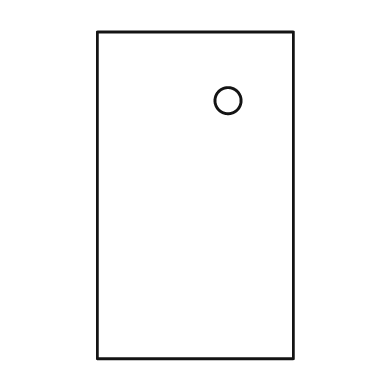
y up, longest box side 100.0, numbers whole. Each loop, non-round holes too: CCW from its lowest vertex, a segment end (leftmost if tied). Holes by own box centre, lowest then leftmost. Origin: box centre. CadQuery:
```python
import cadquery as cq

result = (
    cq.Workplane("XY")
    .moveTo(-30.0, -50.0)
    .lineTo(30.0, -50.0)
    .lineTo(30.0, 50.0)
    .lineTo(-30.0, 50.0)
    .close()
    .moveTo(10.0, 29.0)
    .circle(4.0)
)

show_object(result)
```